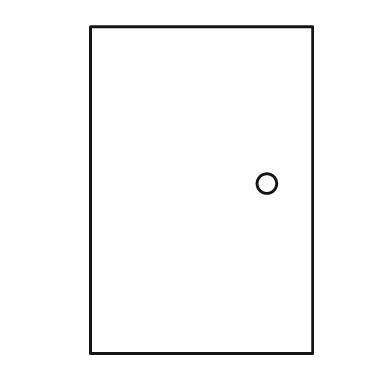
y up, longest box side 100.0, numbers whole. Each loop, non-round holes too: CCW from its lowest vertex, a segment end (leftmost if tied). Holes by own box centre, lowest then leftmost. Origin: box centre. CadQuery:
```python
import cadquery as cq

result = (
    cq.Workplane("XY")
    .moveTo(-34.0, -50.0)
    .lineTo(34.0, -50.0)
    .lineTo(34.0, 50.0)
    .lineTo(-34.0, 50.0)
    .close()
    .moveTo(20.0, 2.0)
    .circle(3.0)
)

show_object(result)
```